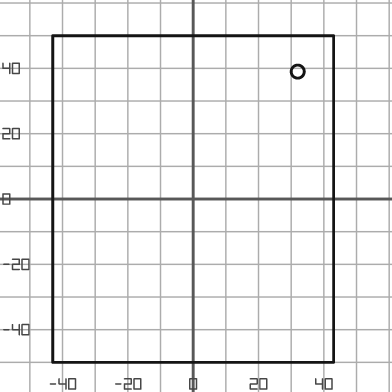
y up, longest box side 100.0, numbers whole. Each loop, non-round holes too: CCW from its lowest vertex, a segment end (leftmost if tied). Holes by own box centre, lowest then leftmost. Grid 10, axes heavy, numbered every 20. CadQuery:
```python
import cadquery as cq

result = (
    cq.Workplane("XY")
    .moveTo(-43.0, -50.0)
    .lineTo(43.0, -50.0)
    .lineTo(43.0, 50.0)
    .lineTo(-43.0, 50.0)
    .close()
    .moveTo(32.0, 39.0)
    .circle(2.0)
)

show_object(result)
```